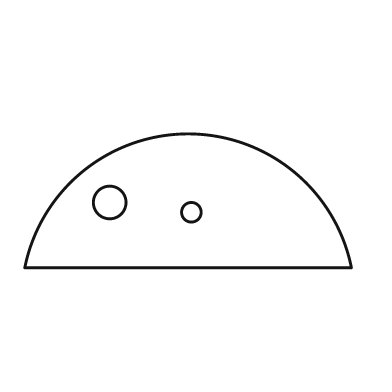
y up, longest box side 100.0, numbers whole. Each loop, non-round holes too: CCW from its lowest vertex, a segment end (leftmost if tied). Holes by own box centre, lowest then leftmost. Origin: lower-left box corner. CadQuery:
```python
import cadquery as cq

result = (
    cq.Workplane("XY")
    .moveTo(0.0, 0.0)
    .lineTo(100.0, 0.0)
    .threePointArc((50.0, 41.0), (0.0, 0.0))
    .close()
    .moveTo(51.0, 17.0)
    .circle(3.0)
    .moveTo(26.0, 20.0)
    .circle(5.0)
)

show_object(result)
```